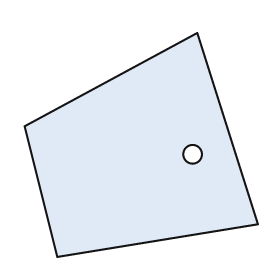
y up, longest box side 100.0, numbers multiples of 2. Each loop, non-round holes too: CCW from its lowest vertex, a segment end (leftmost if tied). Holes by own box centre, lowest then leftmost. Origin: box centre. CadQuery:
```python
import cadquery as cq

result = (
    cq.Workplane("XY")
    .moveTo(-36.0, -48.0)
    .lineTo(50.0, -34.0)
    .lineTo(24.0, 48.0)
    .lineTo(-50.0, 8.0)
    .close()
    .moveTo(22.0, -4.0)
    .circle(4.0)
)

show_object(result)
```